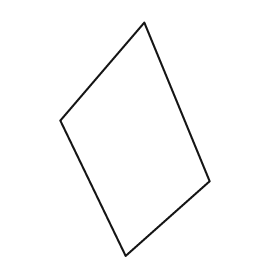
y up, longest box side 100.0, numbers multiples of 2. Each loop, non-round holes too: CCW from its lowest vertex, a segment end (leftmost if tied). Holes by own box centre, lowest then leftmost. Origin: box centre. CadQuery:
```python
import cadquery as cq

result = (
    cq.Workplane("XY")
    .moveTo(-4.0, -50.0)
    .lineTo(32.0, -18.0)
    .lineTo(4.0, 50.0)
    .lineTo(-32.0, 8.0)
    .close()
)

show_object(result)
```